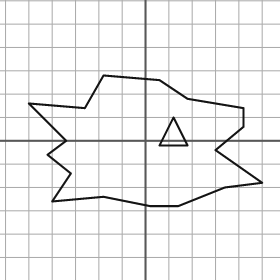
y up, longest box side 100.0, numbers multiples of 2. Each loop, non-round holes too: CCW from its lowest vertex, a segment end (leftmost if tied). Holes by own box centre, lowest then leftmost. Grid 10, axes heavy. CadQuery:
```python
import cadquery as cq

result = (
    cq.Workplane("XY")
    .moveTo(2.0, -28.0)
    .lineTo(14.0, -28.0)
    .lineTo(34.0, -20.0)
    .lineTo(50.0, -18.0)
    .lineTo(30.0, -4.0)
    .lineTo(42.0, 6.0)
    .lineTo(42.0, 14.0)
    .lineTo(18.0, 18.0)
    .lineTo(6.0, 26.0)
    .lineTo(-18.0, 28.0)
    .lineTo(-26.0, 14.0)
    .lineTo(-50.0, 16.0)
    .lineTo(-34.0, 0.0)
    .lineTo(-42.0, -6.0)
    .lineTo(-32.0, -14.0)
    .lineTo(-40.0, -26.0)
    .lineTo(-18.0, -24.0)
    .close()
    .moveTo(6.0, -2.0)
    .lineTo(18.0, -2.0)
    .lineTo(12.0, 10.0)
    .close()
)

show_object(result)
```